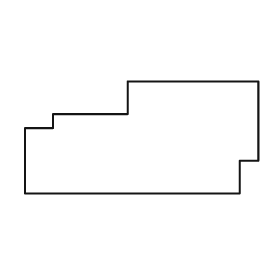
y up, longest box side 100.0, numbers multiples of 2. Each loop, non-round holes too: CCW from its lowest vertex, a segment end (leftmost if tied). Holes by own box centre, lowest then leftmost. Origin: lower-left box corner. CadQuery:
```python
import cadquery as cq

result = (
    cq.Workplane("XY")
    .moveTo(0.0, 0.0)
    .lineTo(92.0, 0.0)
    .lineTo(92.0, 14.0)
    .lineTo(100.0, 14.0)
    .lineTo(100.0, 48.0)
    .lineTo(44.0, 48.0)
    .lineTo(44.0, 34.0)
    .lineTo(12.0, 34.0)
    .lineTo(12.0, 28.0)
    .lineTo(0.0, 28.0)
    .close()
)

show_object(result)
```